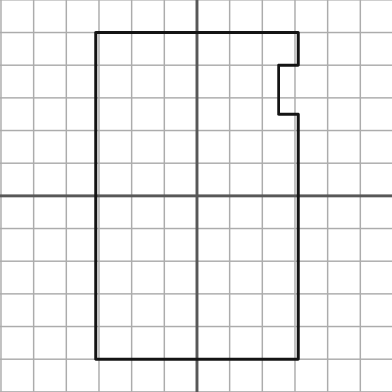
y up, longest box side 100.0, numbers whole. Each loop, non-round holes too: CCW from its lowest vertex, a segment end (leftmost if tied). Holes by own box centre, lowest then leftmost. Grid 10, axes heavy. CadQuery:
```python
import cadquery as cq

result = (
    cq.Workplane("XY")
    .moveTo(-31.0, -50.0)
    .lineTo(31.0, -50.0)
    .lineTo(31.0, 25.0)
    .lineTo(25.0, 25.0)
    .lineTo(25.0, 40.0)
    .lineTo(31.0, 40.0)
    .lineTo(31.0, 50.0)
    .lineTo(-31.0, 50.0)
    .close()
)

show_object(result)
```